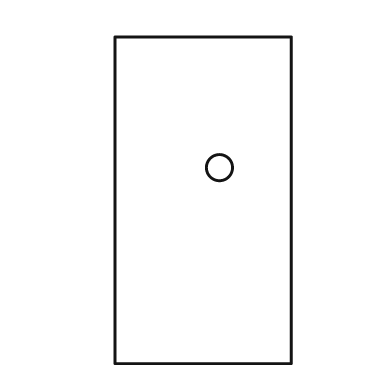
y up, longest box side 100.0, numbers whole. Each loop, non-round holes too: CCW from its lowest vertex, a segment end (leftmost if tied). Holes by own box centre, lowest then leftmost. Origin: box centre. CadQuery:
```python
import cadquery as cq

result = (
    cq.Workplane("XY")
    .moveTo(-27.0, -50.0)
    .lineTo(27.0, -50.0)
    .lineTo(27.0, 50.0)
    .lineTo(-27.0, 50.0)
    .close()
    .moveTo(5.0, 10.0)
    .circle(4.0)
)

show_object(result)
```